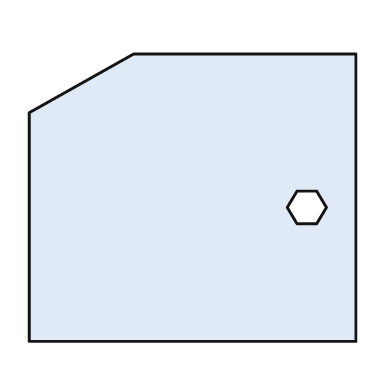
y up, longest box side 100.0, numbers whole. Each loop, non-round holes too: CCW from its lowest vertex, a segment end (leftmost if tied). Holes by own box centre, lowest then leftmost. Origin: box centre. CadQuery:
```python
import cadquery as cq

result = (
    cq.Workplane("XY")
    .moveTo(-50.0, -44.0)
    .lineTo(50.0, -44.0)
    .lineTo(50.0, 44.0)
    .lineTo(-18.0, 44.0)
    .lineTo(-50.0, 26.0)
    .close()
    .moveTo(32.0, -8.0)
    .lineTo(38.0, -8.0)
    .lineTo(41.0, -3.0)
    .lineTo(38.0, 2.0)
    .lineTo(32.0, 2.0)
    .lineTo(29.0, -3.0)
    .close()
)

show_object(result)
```